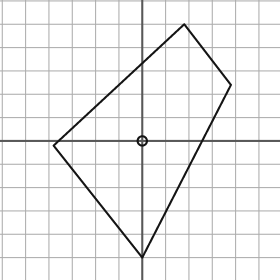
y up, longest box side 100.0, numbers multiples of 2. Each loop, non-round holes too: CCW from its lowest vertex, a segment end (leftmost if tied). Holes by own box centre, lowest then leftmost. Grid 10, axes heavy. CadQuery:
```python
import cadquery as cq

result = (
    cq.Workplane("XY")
    .moveTo(0.0, -50.0)
    .lineTo(38.0, 24.0)
    .lineTo(18.0, 50.0)
    .lineTo(-38.0, -2.0)
    .close()
    .moveTo(0.0, 0.0)
    .circle(2.0)
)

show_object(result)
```